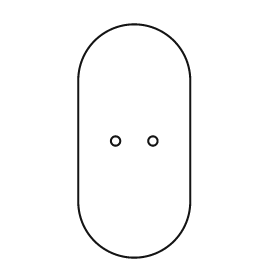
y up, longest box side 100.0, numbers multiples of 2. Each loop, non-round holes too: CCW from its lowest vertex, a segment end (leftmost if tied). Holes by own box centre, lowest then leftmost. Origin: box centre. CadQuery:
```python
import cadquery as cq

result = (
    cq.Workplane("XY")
    .moveTo(-24.0, -26.0)
    .threePointArc((0.0, -50.0), (24.0, -26.0))
    .lineTo(24.0, 26.0)
    .threePointArc((0.0, 50.0), (-24.0, 26.0))
    .close()
    .moveTo(-8.0, 0.0)
    .circle(2.0)
    .moveTo(8.0, 0.0)
    .circle(2.0)
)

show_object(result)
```